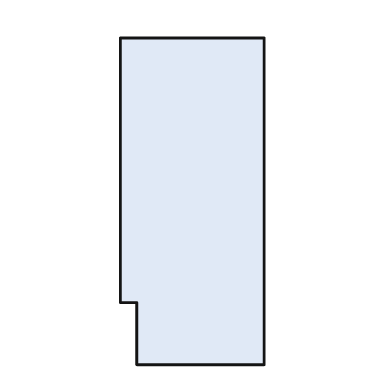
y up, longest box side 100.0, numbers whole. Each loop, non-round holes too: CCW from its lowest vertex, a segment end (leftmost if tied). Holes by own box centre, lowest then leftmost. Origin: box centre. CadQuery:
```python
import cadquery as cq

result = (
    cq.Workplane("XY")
    .moveTo(-17.0, -50.0)
    .lineTo(22.0, -50.0)
    .lineTo(22.0, 50.0)
    .lineTo(-22.0, 50.0)
    .lineTo(-22.0, -31.0)
    .lineTo(-17.0, -31.0)
    .close()
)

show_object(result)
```